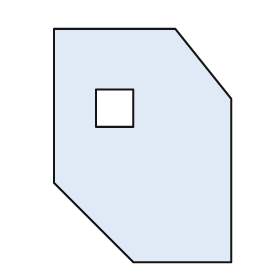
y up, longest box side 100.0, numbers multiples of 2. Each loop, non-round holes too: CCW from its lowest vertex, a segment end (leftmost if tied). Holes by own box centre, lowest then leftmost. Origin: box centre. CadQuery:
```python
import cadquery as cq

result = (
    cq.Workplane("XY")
    .moveTo(-4.0, -50.0)
    .lineTo(38.0, -50.0)
    .lineTo(38.0, 20.0)
    .lineTo(14.0, 50.0)
    .lineTo(-38.0, 50.0)
    .lineTo(-38.0, -16.0)
    .close()
    .moveTo(-20.0, 8.0)
    .lineTo(-4.0, 8.0)
    .lineTo(-4.0, 24.0)
    .lineTo(-20.0, 24.0)
    .close()
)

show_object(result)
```